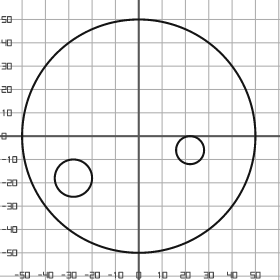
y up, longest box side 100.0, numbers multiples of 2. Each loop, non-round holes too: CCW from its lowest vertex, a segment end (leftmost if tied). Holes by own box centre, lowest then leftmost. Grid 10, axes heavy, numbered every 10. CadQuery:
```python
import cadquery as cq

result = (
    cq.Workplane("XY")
    .moveTo(0.0, 0.0)
    .circle(50.0)
    .moveTo(-28.0, -18.0)
    .circle(8.0)
    .moveTo(22.0, -6.0)
    .circle(6.0)
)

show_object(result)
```